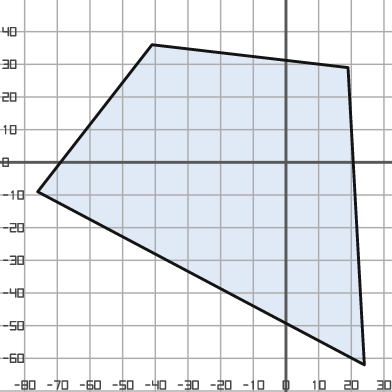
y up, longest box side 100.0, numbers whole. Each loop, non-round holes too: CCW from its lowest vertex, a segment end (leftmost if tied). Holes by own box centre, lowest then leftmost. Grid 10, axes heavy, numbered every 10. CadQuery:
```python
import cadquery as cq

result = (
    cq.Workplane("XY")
    .moveTo(24.0, -62.0)
    .lineTo(19.0, 29.0)
    .lineTo(-41.0, 36.0)
    .lineTo(-76.0, -9.0)
    .close()
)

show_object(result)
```